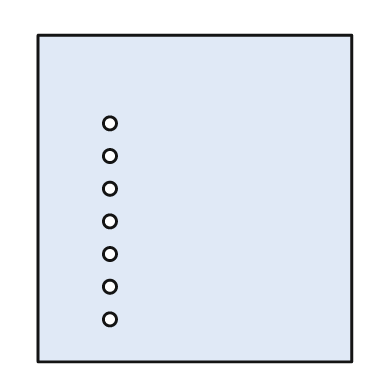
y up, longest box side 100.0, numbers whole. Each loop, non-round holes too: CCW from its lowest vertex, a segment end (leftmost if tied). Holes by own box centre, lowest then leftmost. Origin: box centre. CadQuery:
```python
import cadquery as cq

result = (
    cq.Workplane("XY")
    .moveTo(-48.0, -50.0)
    .lineTo(48.0, -50.0)
    .lineTo(48.0, 50.0)
    .lineTo(-48.0, 50.0)
    .close()
    .moveTo(-26.0, -37.0)
    .circle(2.0)
    .moveTo(-26.0, -27.0)
    .circle(2.0)
    .moveTo(-26.0, -17.0)
    .circle(2.0)
    .moveTo(-26.0, -7.0)
    .circle(2.0)
    .moveTo(-26.0, 3.0)
    .circle(2.0)
    .moveTo(-26.0, 13.0)
    .circle(2.0)
    .moveTo(-26.0, 23.0)
    .circle(2.0)
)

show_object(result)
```